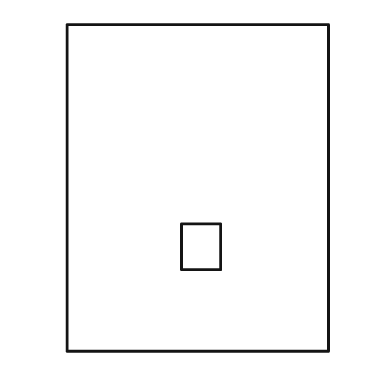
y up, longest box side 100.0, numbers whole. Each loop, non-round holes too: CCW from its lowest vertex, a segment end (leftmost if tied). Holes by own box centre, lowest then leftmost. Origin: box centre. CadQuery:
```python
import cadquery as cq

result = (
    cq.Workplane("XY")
    .moveTo(-40.0, -50.0)
    .lineTo(40.0, -50.0)
    .lineTo(40.0, 50.0)
    .lineTo(-40.0, 50.0)
    .close()
    .moveTo(-5.0, -25.0)
    .lineTo(7.0, -25.0)
    .lineTo(7.0, -11.0)
    .lineTo(-5.0, -11.0)
    .close()
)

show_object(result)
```